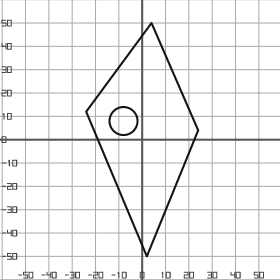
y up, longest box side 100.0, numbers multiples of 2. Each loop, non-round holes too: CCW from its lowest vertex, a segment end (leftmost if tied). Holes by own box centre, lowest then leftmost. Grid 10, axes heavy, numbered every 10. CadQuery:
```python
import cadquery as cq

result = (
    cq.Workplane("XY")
    .moveTo(2.0, -50.0)
    .lineTo(24.0, 4.0)
    .lineTo(4.0, 50.0)
    .lineTo(-24.0, 12.0)
    .close()
    .moveTo(-8.0, 8.0)
    .circle(6.0)
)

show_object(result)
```